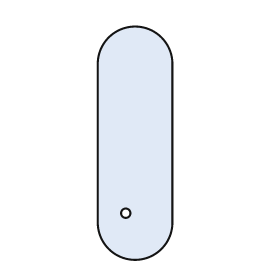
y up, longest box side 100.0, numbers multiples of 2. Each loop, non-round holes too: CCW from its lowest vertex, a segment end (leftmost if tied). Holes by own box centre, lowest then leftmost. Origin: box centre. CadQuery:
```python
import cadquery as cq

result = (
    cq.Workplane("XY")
    .moveTo(-16.0, -34.0)
    .threePointArc((0.0, -50.0), (16.0, -34.0))
    .lineTo(16.0, 34.0)
    .threePointArc((0.0, 50.0), (-16.0, 34.0))
    .close()
    .moveTo(-4.0, -30.0)
    .circle(2.0)
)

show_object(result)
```